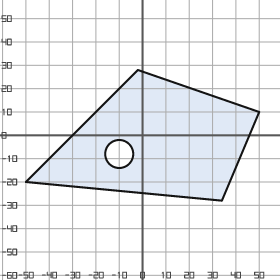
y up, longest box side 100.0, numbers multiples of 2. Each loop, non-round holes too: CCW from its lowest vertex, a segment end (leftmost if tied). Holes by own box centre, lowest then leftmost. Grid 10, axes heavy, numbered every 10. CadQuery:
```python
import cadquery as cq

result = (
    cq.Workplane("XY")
    .moveTo(34.0, -28.0)
    .lineTo(50.0, 10.0)
    .lineTo(-2.0, 28.0)
    .lineTo(-50.0, -20.0)
    .close()
    .moveTo(-10.0, -8.0)
    .circle(6.0)
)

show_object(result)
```